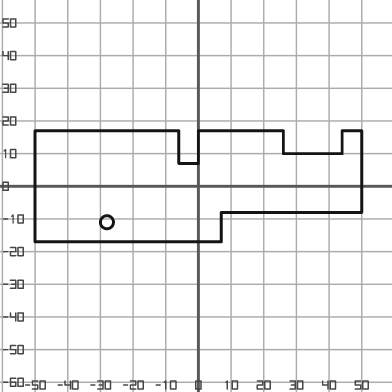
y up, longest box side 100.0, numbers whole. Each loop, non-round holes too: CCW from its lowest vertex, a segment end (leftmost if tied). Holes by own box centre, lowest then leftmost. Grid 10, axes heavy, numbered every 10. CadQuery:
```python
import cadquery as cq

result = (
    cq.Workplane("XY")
    .moveTo(-50.0, -17.0)
    .lineTo(7.0, -17.0)
    .lineTo(7.0, -8.0)
    .lineTo(50.0, -8.0)
    .lineTo(50.0, 17.0)
    .lineTo(44.0, 17.0)
    .lineTo(44.0, 10.0)
    .lineTo(26.0, 10.0)
    .lineTo(26.0, 17.0)
    .lineTo(0.0, 17.0)
    .lineTo(0.0, 7.0)
    .lineTo(-6.0, 7.0)
    .lineTo(-6.0, 17.0)
    .lineTo(-50.0, 17.0)
    .close()
    .moveTo(-28.0, -11.0)
    .circle(2.0)
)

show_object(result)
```